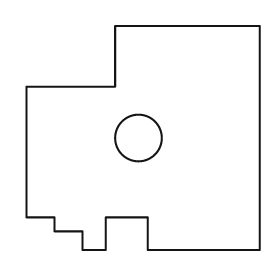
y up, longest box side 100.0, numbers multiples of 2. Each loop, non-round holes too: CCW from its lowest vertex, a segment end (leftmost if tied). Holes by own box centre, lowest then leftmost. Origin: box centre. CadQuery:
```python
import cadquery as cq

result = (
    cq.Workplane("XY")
    .moveTo(-26.0, -48.0)
    .lineTo(-16.0, -48.0)
    .lineTo(-16.0, -34.0)
    .lineTo(2.0, -34.0)
    .lineTo(2.0, -48.0)
    .lineTo(50.0, -48.0)
    .lineTo(50.0, 48.0)
    .lineTo(-12.0, 48.0)
    .lineTo(-12.0, 22.0)
    .lineTo(-50.0, 22.0)
    .lineTo(-50.0, -34.0)
    .lineTo(-38.0, -34.0)
    .lineTo(-38.0, -40.0)
    .lineTo(-26.0, -40.0)
    .close()
    .moveTo(-2.0, 0.0)
    .circle(10.0)
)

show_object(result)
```